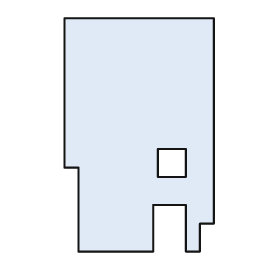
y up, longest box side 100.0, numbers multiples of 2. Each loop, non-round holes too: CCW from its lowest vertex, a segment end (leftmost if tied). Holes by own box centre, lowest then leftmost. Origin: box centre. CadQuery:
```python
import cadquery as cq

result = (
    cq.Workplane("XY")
    .moveTo(-26.0, -50.0)
    .lineTo(6.0, -50.0)
    .lineTo(6.0, -30.0)
    .lineTo(20.0, -30.0)
    .lineTo(20.0, -50.0)
    .lineTo(26.0, -50.0)
    .lineTo(26.0, -38.0)
    .lineTo(32.0, -38.0)
    .lineTo(32.0, 50.0)
    .lineTo(-32.0, 50.0)
    .lineTo(-32.0, -14.0)
    .lineTo(-26.0, -14.0)
    .close()
    .moveTo(8.0, -18.0)
    .lineTo(20.0, -18.0)
    .lineTo(20.0, -6.0)
    .lineTo(8.0, -6.0)
    .close()
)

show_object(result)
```